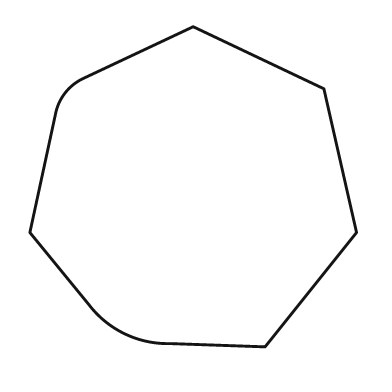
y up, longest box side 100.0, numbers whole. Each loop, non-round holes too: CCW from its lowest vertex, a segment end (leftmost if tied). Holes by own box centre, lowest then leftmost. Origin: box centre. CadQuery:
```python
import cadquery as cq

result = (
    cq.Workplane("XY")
    .moveTo(22.0, -49.0)
    .lineTo(50.0, -14.0)
    .lineTo(40.0, 30.0)
    .lineTo(0.0, 49.0)
    .lineTo(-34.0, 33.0)
    .threePointArc((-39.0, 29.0), (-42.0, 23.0))
    .lineTo(-50.0, -14.0)
    .lineTo(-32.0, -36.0)
    .threePointArc((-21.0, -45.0), (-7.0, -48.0))
    .close()
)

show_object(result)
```